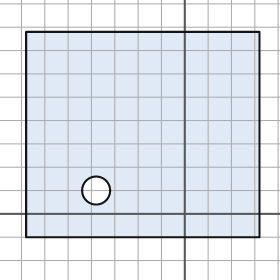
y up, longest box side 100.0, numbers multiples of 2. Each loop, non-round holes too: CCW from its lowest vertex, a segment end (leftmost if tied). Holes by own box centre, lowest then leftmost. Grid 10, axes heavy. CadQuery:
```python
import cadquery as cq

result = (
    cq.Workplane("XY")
    .moveTo(-68.0, -10.0)
    .lineTo(32.0, -10.0)
    .lineTo(32.0, 78.0)
    .lineTo(-68.0, 78.0)
    .close()
    .moveTo(-38.0, 10.0)
    .circle(6.0)
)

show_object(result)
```